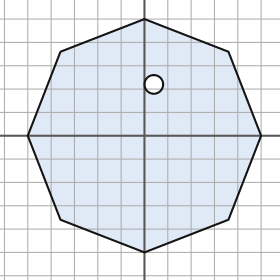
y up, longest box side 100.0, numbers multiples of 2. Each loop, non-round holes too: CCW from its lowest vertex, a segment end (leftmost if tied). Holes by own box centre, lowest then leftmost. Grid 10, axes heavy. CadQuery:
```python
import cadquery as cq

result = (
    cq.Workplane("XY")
    .moveTo(0.0, -50.0)
    .lineTo(36.0, -36.0)
    .lineTo(50.0, 0.0)
    .lineTo(36.0, 36.0)
    .lineTo(0.0, 50.0)
    .lineTo(-36.0, 36.0)
    .lineTo(-50.0, 0.0)
    .lineTo(-36.0, -36.0)
    .close()
    .moveTo(4.0, 22.0)
    .circle(4.0)
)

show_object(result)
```